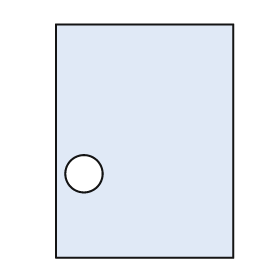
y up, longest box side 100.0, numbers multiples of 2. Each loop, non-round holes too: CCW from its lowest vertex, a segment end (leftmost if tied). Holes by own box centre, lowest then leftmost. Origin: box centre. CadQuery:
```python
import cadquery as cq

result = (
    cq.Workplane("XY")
    .moveTo(-38.0, -50.0)
    .lineTo(38.0, -50.0)
    .lineTo(38.0, 50.0)
    .lineTo(-38.0, 50.0)
    .close()
    .moveTo(-26.0, -14.0)
    .circle(8.0)
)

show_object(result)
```